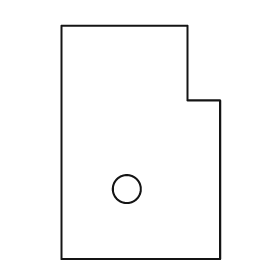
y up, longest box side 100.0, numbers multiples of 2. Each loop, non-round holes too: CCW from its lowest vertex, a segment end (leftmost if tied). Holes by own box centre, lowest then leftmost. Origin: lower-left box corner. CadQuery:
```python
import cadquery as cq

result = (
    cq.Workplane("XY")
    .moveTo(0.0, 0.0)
    .lineTo(68.0, 0.0)
    .lineTo(68.0, 68.0)
    .lineTo(54.0, 68.0)
    .lineTo(54.0, 100.0)
    .lineTo(0.0, 100.0)
    .close()
    .moveTo(28.0, 30.0)
    .circle(6.0)
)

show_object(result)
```